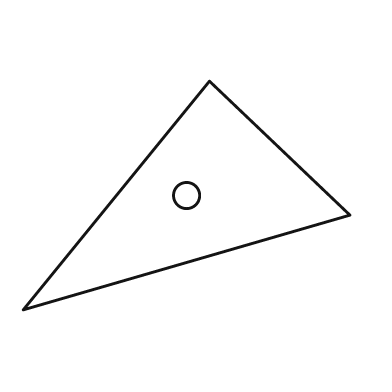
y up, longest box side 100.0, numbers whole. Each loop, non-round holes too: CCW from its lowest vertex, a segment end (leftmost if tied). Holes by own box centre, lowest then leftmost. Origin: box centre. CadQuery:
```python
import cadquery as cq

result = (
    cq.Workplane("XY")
    .moveTo(-50.0, -35.0)
    .lineTo(50.0, -6.0)
    .lineTo(7.0, 35.0)
    .close()
    .moveTo(0.0, 0.0)
    .circle(4.0)
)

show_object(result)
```